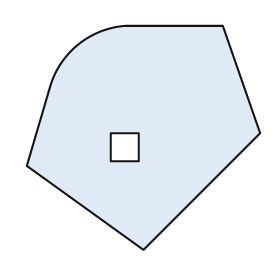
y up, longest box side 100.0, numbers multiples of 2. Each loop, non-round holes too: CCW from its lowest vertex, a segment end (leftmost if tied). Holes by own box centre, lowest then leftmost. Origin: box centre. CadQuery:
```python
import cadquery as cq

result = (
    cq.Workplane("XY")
    .moveTo(0.0, -48.0)
    .lineTo(50.0, 2.0)
    .lineTo(34.0, 48.0)
    .lineTo(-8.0, 48.0)
    .threePointArc((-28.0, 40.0), (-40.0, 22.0))
    .lineTo(-50.0, -12.0)
    .close()
    .moveTo(-14.0, -10.0)
    .lineTo(-2.0, -10.0)
    .lineTo(-2.0, 2.0)
    .lineTo(-14.0, 2.0)
    .close()
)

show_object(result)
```